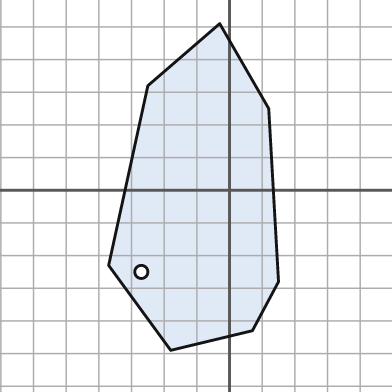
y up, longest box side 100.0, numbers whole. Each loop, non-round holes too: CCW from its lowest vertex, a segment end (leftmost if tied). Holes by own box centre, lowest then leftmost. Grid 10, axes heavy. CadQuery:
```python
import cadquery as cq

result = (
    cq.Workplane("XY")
    .moveTo(-18.0, -49.0)
    .lineTo(7.0, -43.0)
    .lineTo(15.0, -28.0)
    .lineTo(12.0, 25.0)
    .lineTo(-3.0, 51.0)
    .lineTo(-25.0, 32.0)
    .lineTo(-37.0, -23.0)
    .close()
    .moveTo(-27.0, -25.0)
    .circle(2.0)
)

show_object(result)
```